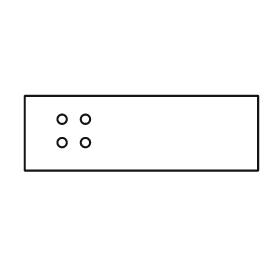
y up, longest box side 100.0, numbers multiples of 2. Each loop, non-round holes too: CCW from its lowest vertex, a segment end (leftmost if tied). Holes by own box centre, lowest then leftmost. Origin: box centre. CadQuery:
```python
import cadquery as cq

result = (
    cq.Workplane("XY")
    .moveTo(-50.0, -16.0)
    .lineTo(50.0, -16.0)
    .lineTo(50.0, 16.0)
    .lineTo(-50.0, 16.0)
    .close()
    .moveTo(-34.0, -4.0)
    .circle(2.0)
    .moveTo(-24.0, -4.0)
    .circle(2.0)
    .moveTo(-34.0, 6.0)
    .circle(2.0)
    .moveTo(-24.0, 6.0)
    .circle(2.0)
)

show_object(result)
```